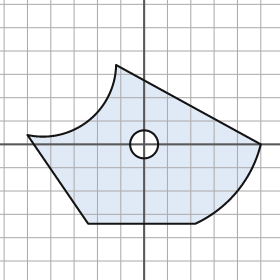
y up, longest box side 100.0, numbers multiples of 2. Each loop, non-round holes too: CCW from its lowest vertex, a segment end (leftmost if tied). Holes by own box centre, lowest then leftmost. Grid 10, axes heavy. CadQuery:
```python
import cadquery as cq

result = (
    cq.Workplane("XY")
    .moveTo(-24.0, -34.0)
    .lineTo(22.0, -34.0)
    .threePointArc((40.0, -20.0), (50.0, 0.0))
    .lineTo(-12.0, 34.0)
    .threePointArc((-24.0, 10.0), (-50.0, 4.0))
    .close()
    .moveTo(0.0, 0.0)
    .circle(6.0)
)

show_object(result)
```